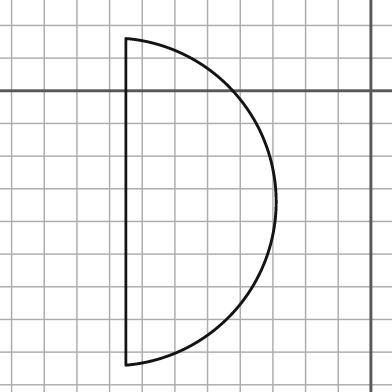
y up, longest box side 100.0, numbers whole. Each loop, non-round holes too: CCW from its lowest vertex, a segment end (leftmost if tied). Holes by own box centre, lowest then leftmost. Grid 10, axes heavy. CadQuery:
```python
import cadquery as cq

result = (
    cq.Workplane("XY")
    .moveTo(-75.0, -84.0)
    .threePointArc((-29.0, -34.0), (-75.0, 16.0))
    .close()
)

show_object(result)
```